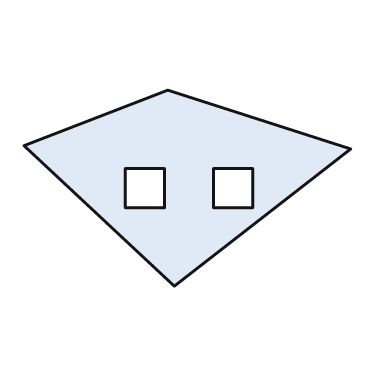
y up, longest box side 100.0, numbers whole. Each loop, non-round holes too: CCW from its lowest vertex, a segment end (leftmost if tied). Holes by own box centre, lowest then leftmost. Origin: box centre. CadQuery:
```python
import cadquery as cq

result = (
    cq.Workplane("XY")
    .moveTo(-4.0, -30.0)
    .lineTo(50.0, 12.0)
    .lineTo(-6.0, 30.0)
    .lineTo(-50.0, 13.0)
    .close()
    .moveTo(-19.0, -6.0)
    .lineTo(-7.0, -6.0)
    .lineTo(-7.0, 6.0)
    .lineTo(-19.0, 6.0)
    .close()
    .moveTo(8.0, -6.0)
    .lineTo(20.0, -6.0)
    .lineTo(20.0, 6.0)
    .lineTo(8.0, 6.0)
    .close()
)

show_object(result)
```